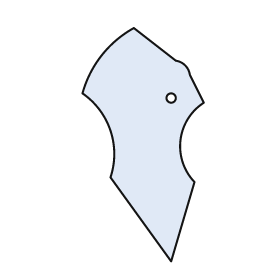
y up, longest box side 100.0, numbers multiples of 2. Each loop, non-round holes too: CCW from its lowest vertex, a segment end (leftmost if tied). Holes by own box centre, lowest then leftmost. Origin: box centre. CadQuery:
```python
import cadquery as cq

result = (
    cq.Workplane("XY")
    .moveTo(12.0, -50.0)
    .lineTo(22.0, -16.0)
    .threePointArc((16.0, 2.0), (26.0, 18.0))
    .lineTo(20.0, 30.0)
    .threePointArc((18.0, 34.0), (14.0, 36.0))
    .lineTo(-4.0, 50.0)
    .threePointArc((-18.0, 38.0), (-26.0, 22.0))
    .threePointArc((-14.0, 6.0), (-14.0, -14.0))
    .close()
    .moveTo(12.0, 20.0)
    .circle(2.0)
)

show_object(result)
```